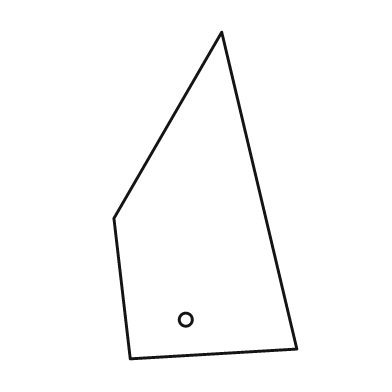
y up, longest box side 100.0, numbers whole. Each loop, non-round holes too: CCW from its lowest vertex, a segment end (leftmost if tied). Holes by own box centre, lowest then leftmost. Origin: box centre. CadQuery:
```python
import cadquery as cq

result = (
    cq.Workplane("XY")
    .moveTo(-23.0, -50.0)
    .lineTo(28.0, -47.0)
    .lineTo(5.0, 50.0)
    .lineTo(-28.0, -7.0)
    .close()
    .moveTo(-6.0, -38.0)
    .circle(2.0)
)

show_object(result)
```